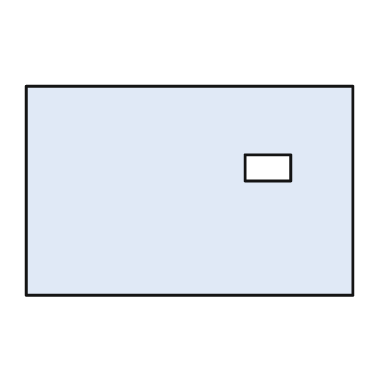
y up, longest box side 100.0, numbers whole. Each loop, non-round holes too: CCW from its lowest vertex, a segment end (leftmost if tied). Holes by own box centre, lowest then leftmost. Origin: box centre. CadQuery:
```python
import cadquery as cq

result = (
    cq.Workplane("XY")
    .moveTo(-50.0, -32.0)
    .lineTo(50.0, -32.0)
    .lineTo(50.0, 32.0)
    .lineTo(-50.0, 32.0)
    .close()
    .moveTo(17.0, 3.0)
    .lineTo(31.0, 3.0)
    .lineTo(31.0, 11.0)
    .lineTo(17.0, 11.0)
    .close()
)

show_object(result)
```